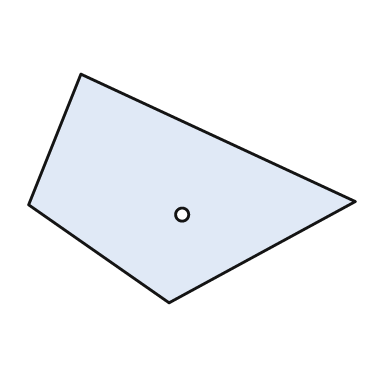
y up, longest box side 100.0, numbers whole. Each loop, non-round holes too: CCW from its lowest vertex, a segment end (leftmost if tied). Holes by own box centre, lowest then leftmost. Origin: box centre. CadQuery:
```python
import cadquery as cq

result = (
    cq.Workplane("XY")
    .moveTo(-7.0, -35.0)
    .lineTo(50.0, -4.0)
    .lineTo(-34.0, 35.0)
    .lineTo(-50.0, -5.0)
    .close()
    .moveTo(-3.0, -8.0)
    .circle(2.0)
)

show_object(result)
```